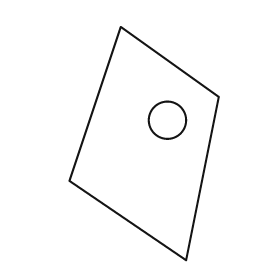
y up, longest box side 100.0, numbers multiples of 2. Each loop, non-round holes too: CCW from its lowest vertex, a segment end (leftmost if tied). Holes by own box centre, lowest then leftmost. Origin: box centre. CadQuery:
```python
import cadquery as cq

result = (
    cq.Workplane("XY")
    .moveTo(18.0, -50.0)
    .lineTo(32.0, 20.0)
    .lineTo(-10.0, 50.0)
    .lineTo(-32.0, -16.0)
    .close()
    .moveTo(10.0, 10.0)
    .circle(8.0)
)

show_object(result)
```